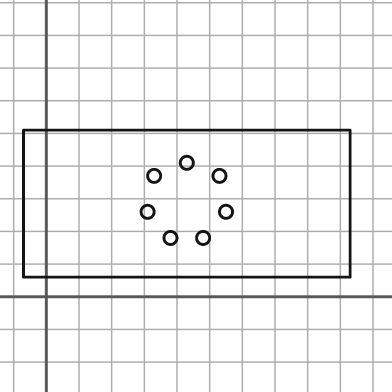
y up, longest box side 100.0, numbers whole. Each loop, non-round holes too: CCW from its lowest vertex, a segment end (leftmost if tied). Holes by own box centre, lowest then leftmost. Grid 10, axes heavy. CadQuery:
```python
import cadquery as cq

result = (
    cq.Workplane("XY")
    .moveTo(-7.0, 6.0)
    .lineTo(93.0, 6.0)
    .lineTo(93.0, 51.0)
    .lineTo(-7.0, 51.0)
    .close()
    .moveTo(38.0, 18.0)
    .circle(2.0)
    .moveTo(48.0, 18.0)
    .circle(2.0)
    .moveTo(31.0, 26.0)
    .circle(2.0)
    .moveTo(55.0, 26.0)
    .circle(2.0)
    .moveTo(33.0, 37.0)
    .circle(2.0)
    .moveTo(53.0, 37.0)
    .circle(2.0)
    .moveTo(43.0, 41.0)
    .circle(2.0)
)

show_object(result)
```